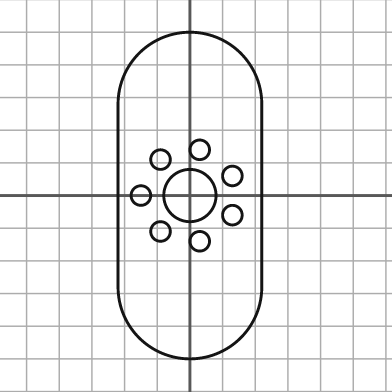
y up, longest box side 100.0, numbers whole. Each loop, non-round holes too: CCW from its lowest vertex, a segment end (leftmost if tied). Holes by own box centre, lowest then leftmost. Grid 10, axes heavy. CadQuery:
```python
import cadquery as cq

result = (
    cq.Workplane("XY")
    .moveTo(-22.0, -28.0)
    .threePointArc((0.0, -50.0), (22.0, -28.0))
    .lineTo(22.0, 28.0)
    .threePointArc((0.0, 50.0), (-22.0, 28.0))
    .close()
    .moveTo(3.0, -14.0)
    .circle(3.0)
    .moveTo(-9.0, -11.0)
    .circle(3.0)
    .moveTo(13.0, -6.0)
    .circle(3.0)
    .moveTo(-15.0, 0.0)
    .circle(3.0)
    .moveTo(0.0, 0.0)
    .circle(8.0)
    .moveTo(13.0, 6.0)
    .circle(3.0)
    .moveTo(-9.0, 11.0)
    .circle(3.0)
    .moveTo(3.0, 14.0)
    .circle(3.0)
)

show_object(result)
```